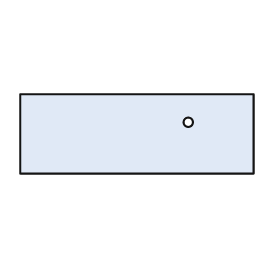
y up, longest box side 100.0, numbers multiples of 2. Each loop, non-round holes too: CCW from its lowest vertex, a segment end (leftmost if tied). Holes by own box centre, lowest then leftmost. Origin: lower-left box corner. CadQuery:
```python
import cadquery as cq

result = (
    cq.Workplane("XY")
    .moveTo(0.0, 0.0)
    .lineTo(100.0, 0.0)
    .lineTo(100.0, 34.0)
    .lineTo(0.0, 34.0)
    .close()
    .moveTo(72.0, 22.0)
    .circle(2.0)
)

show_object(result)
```